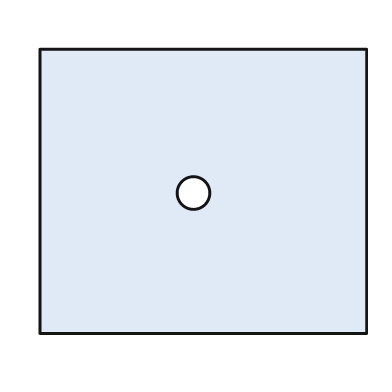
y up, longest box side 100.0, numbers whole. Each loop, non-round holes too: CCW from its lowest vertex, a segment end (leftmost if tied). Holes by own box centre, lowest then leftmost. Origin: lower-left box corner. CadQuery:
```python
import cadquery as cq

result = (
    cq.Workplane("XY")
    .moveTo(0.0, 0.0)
    .lineTo(100.0, 0.0)
    .lineTo(100.0, 87.0)
    .lineTo(0.0, 87.0)
    .close()
    .moveTo(47.0, 43.0)
    .circle(5.0)
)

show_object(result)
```